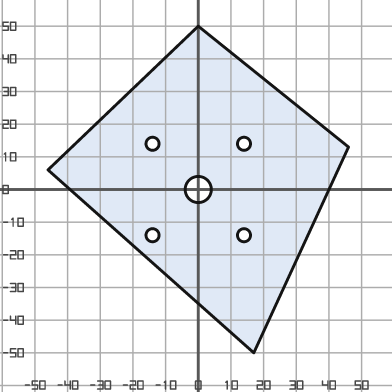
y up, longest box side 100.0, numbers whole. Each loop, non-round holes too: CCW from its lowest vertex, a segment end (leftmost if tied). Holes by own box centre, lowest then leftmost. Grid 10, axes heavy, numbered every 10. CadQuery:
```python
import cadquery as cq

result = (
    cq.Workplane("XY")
    .moveTo(17.0, -50.0)
    .lineTo(46.0, 13.0)
    .lineTo(0.0, 50.0)
    .lineTo(-46.0, 6.0)
    .close()
    .moveTo(-14.0, -14.0)
    .circle(2.0)
    .moveTo(14.0, -14.0)
    .circle(2.0)
    .moveTo(0.0, 0.0)
    .circle(4.0)
    .moveTo(-14.0, 14.0)
    .circle(2.0)
    .moveTo(14.0, 14.0)
    .circle(2.0)
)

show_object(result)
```